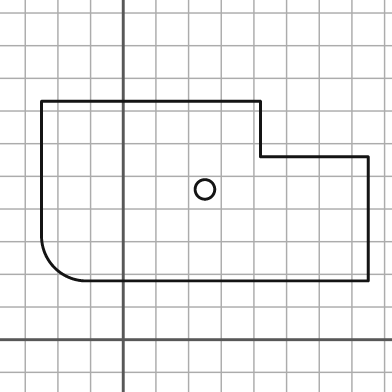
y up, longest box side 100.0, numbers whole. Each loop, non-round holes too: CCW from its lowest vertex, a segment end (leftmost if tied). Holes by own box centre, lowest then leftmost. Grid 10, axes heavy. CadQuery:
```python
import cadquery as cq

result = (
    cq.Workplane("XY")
    .moveTo(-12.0, 18.0)
    .lineTo(75.0, 18.0)
    .lineTo(75.0, 56.0)
    .lineTo(42.0, 56.0)
    .lineTo(42.0, 73.0)
    .lineTo(-25.0, 73.0)
    .lineTo(-25.0, 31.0)
    .threePointArc((-21.0, 22.0), (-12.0, 18.0))
    .close()
    .moveTo(25.0, 46.0)
    .circle(3.0)
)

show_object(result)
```